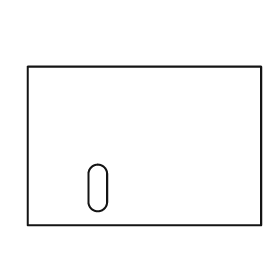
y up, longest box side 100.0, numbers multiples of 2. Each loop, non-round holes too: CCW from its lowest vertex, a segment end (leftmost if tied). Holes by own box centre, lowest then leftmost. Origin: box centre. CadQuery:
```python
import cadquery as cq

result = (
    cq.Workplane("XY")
    .moveTo(-50.0, -34.0)
    .lineTo(50.0, -34.0)
    .lineTo(50.0, 34.0)
    .lineTo(-50.0, 34.0)
    .close()
    .moveTo(-24.0, -24.0)
    .threePointArc((-20.0, -28.0), (-16.0, -24.0))
    .lineTo(-16.0, -12.0)
    .threePointArc((-20.0, -8.0), (-24.0, -12.0))
    .close()
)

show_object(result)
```